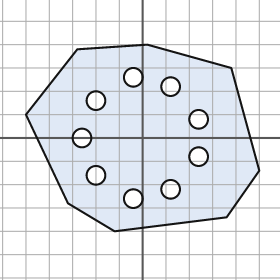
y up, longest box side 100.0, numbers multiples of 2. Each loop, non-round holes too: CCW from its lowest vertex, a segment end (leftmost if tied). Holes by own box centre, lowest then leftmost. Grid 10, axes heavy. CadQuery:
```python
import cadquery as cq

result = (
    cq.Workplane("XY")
    .moveTo(-12.0, -40.0)
    .lineTo(36.0, -34.0)
    .lineTo(50.0, -14.0)
    .lineTo(38.0, 30.0)
    .lineTo(2.0, 40.0)
    .lineTo(-28.0, 38.0)
    .lineTo(-50.0, 10.0)
    .lineTo(-32.0, -28.0)
    .close()
    .moveTo(-4.0, -26.0)
    .circle(4.0)
    .moveTo(12.0, -22.0)
    .circle(4.0)
    .moveTo(-20.0, -16.0)
    .circle(4.0)
    .moveTo(24.0, -8.0)
    .circle(4.0)
    .moveTo(-26.0, 0.0)
    .circle(4.0)
    .moveTo(24.0, 8.0)
    .circle(4.0)
    .moveTo(-20.0, 16.0)
    .circle(4.0)
    .moveTo(12.0, 22.0)
    .circle(4.0)
    .moveTo(-4.0, 26.0)
    .circle(4.0)
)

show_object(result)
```